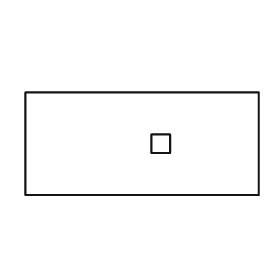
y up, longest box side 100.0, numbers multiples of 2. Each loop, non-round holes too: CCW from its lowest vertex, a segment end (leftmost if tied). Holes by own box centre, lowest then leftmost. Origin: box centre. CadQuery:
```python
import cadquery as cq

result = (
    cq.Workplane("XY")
    .moveTo(-50.0, -22.0)
    .lineTo(50.0, -22.0)
    .lineTo(50.0, 22.0)
    .lineTo(-50.0, 22.0)
    .close()
    .moveTo(4.0, -4.0)
    .lineTo(12.0, -4.0)
    .lineTo(12.0, 4.0)
    .lineTo(4.0, 4.0)
    .close()
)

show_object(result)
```